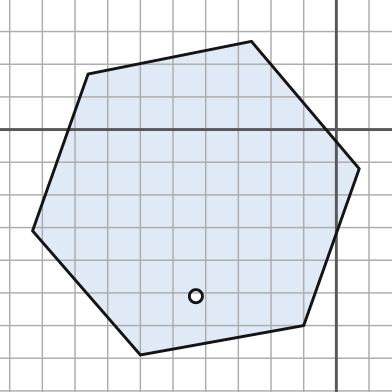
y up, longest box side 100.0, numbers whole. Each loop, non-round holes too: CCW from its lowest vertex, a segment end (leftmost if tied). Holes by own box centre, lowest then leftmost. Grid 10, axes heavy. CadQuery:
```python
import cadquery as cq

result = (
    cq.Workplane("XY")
    .moveTo(-60.0, -69.0)
    .lineTo(-10.0, -60.0)
    .lineTo(7.0, -12.0)
    .lineTo(-26.0, 27.0)
    .lineTo(-76.0, 17.0)
    .lineTo(-93.0, -31.0)
    .close()
    .moveTo(-43.0, -51.0)
    .circle(2.0)
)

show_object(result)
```